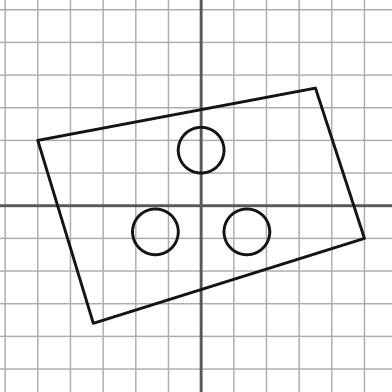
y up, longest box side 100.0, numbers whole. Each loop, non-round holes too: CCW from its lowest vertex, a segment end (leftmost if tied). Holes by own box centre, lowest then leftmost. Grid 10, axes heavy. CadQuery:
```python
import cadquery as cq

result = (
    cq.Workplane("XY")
    .moveTo(-33.0, -36.0)
    .lineTo(50.0, -10.0)
    .lineTo(35.0, 36.0)
    .lineTo(-50.0, 20.0)
    .close()
    .moveTo(-14.0, -8.0)
    .circle(7.0)
    .moveTo(14.0, -8.0)
    .circle(7.0)
    .moveTo(0.0, 17.0)
    .circle(7.0)
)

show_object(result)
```